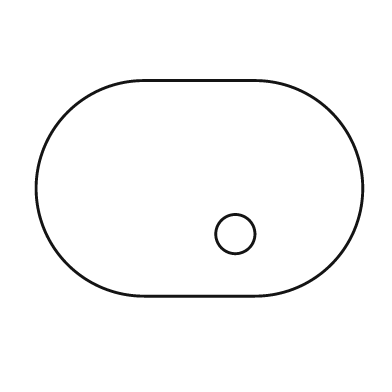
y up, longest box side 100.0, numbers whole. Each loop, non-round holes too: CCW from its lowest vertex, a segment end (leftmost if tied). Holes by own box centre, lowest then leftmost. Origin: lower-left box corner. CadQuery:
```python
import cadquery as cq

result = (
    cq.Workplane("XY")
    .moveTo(33.0, 0.0)
    .lineTo(67.0, 0.0)
    .threePointArc((100.0, 33.0), (67.0, 66.0))
    .lineTo(33.0, 66.0)
    .threePointArc((0.0, 33.0), (33.0, 0.0))
    .close()
    .moveTo(61.0, 19.0)
    .circle(6.0)
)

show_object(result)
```